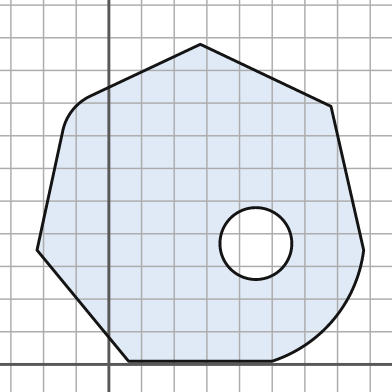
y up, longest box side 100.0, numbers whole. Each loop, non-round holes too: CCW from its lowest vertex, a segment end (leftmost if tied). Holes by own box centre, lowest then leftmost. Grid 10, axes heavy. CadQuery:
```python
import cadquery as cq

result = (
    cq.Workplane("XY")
    .moveTo(6.0, 1.0)
    .lineTo(50.0, 1.0)
    .threePointArc((69.0, 14.0), (78.0, 35.0))
    .lineTo(68.0, 79.0)
    .lineTo(28.0, 98.0)
    .lineTo(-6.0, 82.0)
    .threePointArc((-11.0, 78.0), (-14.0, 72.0))
    .lineTo(-22.0, 35.0)
    .close()
    .moveTo(45.0, 37.0)
    .circle(11.0)
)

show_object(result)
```